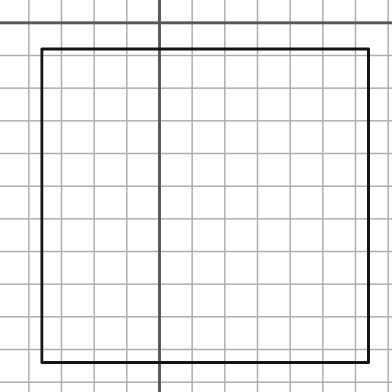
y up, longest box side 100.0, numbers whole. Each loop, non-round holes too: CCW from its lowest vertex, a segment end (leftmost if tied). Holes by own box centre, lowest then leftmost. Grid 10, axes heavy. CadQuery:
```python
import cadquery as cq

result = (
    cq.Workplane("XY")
    .moveTo(-36.0, -104.0)
    .lineTo(64.0, -104.0)
    .lineTo(64.0, -8.0)
    .lineTo(-36.0, -8.0)
    .close()
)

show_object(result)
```